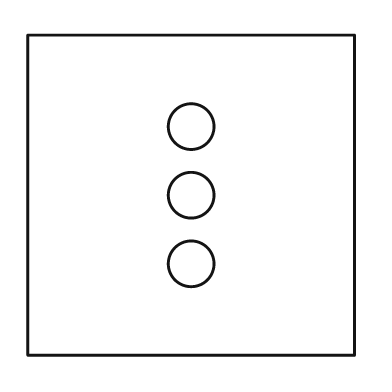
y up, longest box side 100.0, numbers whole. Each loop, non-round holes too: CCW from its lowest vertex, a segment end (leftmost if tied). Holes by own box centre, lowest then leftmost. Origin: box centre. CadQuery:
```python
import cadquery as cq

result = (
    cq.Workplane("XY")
    .moveTo(-50.0, -49.0)
    .lineTo(50.0, -49.0)
    .lineTo(50.0, 49.0)
    .lineTo(-50.0, 49.0)
    .close()
    .moveTo(0.0, -21.0)
    .circle(7.0)
    .moveTo(0.0, 0.0)
    .circle(7.0)
    .moveTo(0.0, 21.0)
    .circle(7.0)
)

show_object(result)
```